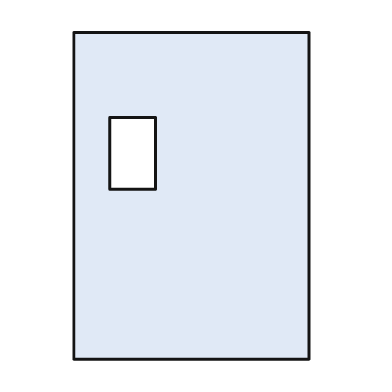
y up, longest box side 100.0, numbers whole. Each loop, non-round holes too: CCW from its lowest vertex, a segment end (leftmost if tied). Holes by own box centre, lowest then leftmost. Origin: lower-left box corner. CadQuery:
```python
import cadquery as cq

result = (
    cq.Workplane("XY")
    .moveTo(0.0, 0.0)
    .lineTo(72.0, 0.0)
    .lineTo(72.0, 100.0)
    .lineTo(0.0, 100.0)
    .close()
    .moveTo(11.0, 52.0)
    .lineTo(25.0, 52.0)
    .lineTo(25.0, 74.0)
    .lineTo(11.0, 74.0)
    .close()
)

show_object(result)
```